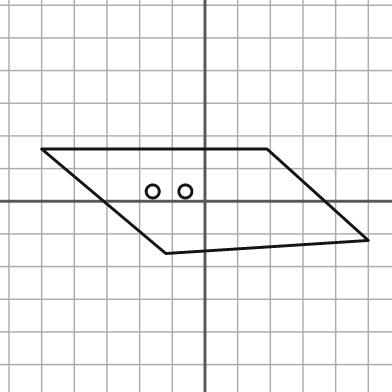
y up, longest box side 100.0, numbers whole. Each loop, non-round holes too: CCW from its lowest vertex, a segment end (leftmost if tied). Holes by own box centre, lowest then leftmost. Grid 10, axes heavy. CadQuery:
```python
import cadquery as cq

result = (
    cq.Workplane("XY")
    .moveTo(-12.0, -16.0)
    .lineTo(50.0, -12.0)
    .lineTo(19.0, 16.0)
    .lineTo(-50.0, 16.0)
    .close()
    .moveTo(-16.0, 3.0)
    .circle(2.0)
    .moveTo(-6.0, 3.0)
    .circle(2.0)
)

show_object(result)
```